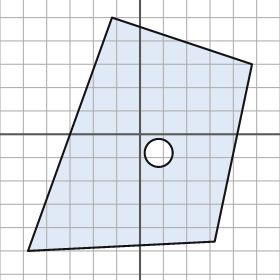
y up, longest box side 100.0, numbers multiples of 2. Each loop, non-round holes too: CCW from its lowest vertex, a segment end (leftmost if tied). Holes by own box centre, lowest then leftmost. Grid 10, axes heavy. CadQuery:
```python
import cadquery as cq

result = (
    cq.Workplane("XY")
    .moveTo(-48.0, -50.0)
    .lineTo(32.0, -46.0)
    .lineTo(48.0, 30.0)
    .lineTo(-12.0, 50.0)
    .close()
    .moveTo(8.0, -8.0)
    .circle(6.0)
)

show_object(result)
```